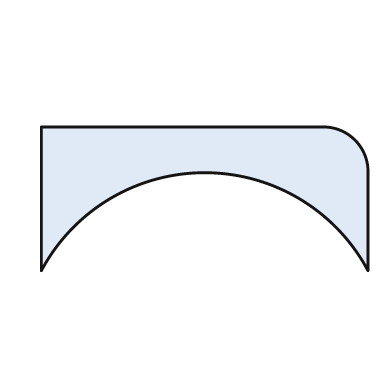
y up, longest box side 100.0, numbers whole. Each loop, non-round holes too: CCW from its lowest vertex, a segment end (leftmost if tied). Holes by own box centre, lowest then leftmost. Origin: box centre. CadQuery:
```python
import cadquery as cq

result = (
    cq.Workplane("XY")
    .moveTo(-50.0, -22.0)
    .threePointArc((0.0, 8.0), (50.0, -22.0))
    .lineTo(50.0, 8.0)
    .threePointArc((46.0, 18.0), (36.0, 22.0))
    .lineTo(-50.0, 22.0)
    .close()
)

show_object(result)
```